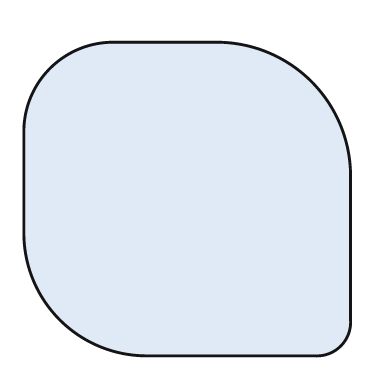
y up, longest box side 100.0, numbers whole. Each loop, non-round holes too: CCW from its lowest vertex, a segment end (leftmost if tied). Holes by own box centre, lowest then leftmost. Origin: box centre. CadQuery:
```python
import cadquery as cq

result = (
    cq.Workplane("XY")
    .moveTo(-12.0, -48.0)
    .lineTo(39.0, -48.0)
    .threePointArc((47.0, -45.0), (50.0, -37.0))
    .lineTo(50.0, 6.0)
    .threePointArc((38.0, 36.0), (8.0, 48.0))
    .lineTo(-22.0, 48.0)
    .threePointArc((-42.0, 40.0), (-50.0, 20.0))
    .lineTo(-50.0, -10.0)
    .threePointArc((-39.0, -37.0), (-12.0, -48.0))
    .close()
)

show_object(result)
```